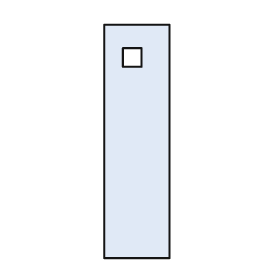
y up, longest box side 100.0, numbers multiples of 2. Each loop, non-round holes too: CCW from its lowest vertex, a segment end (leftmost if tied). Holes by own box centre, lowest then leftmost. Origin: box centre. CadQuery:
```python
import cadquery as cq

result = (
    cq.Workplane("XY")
    .moveTo(-14.0, -50.0)
    .lineTo(14.0, -50.0)
    .lineTo(14.0, 50.0)
    .lineTo(-14.0, 50.0)
    .close()
    .moveTo(-6.0, 32.0)
    .lineTo(2.0, 32.0)
    .lineTo(2.0, 40.0)
    .lineTo(-6.0, 40.0)
    .close()
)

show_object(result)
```